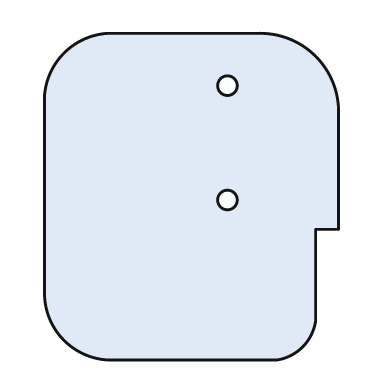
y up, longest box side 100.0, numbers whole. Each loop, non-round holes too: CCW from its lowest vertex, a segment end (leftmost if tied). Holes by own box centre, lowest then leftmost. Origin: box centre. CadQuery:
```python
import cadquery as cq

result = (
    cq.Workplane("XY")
    .moveTo(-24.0, -50.0)
    .lineTo(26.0, -50.0)
    .threePointArc((34.0, -46.0), (38.0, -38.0))
    .lineTo(38.0, -10.0)
    .lineTo(45.0, -10.0)
    .lineTo(45.0, 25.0)
    .threePointArc((38.0, 43.0), (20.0, 50.0))
    .lineTo(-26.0, 50.0)
    .threePointArc((-39.0, 44.0), (-45.0, 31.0))
    .lineTo(-45.0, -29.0)
    .threePointArc((-39.0, -44.0), (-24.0, -50.0))
    .close()
    .moveTo(11.0, -1.0)
    .circle(3.0)
    .moveTo(11.0, 34.0)
    .circle(3.0)
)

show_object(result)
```